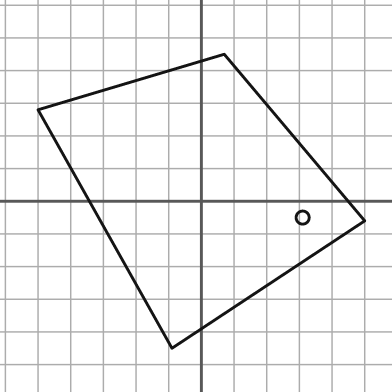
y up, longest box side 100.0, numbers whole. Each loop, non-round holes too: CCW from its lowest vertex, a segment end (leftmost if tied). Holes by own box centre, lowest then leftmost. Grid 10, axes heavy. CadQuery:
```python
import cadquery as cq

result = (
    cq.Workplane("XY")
    .moveTo(-9.0, -45.0)
    .lineTo(50.0, -6.0)
    .lineTo(7.0, 45.0)
    .lineTo(-50.0, 28.0)
    .close()
    .moveTo(31.0, -5.0)
    .circle(2.0)
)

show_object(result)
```